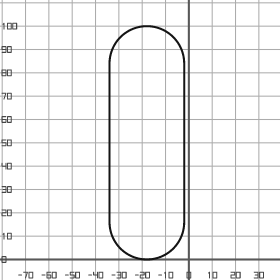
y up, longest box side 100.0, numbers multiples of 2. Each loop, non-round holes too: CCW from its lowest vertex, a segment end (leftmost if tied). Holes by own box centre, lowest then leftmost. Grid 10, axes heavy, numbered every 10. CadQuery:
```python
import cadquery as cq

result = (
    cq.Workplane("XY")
    .moveTo(-34.0, 16.0)
    .threePointArc((-18.0, 0.0), (-2.0, 16.0))
    .lineTo(-2.0, 84.0)
    .threePointArc((-18.0, 100.0), (-34.0, 84.0))
    .close()
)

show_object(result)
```